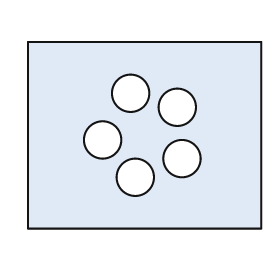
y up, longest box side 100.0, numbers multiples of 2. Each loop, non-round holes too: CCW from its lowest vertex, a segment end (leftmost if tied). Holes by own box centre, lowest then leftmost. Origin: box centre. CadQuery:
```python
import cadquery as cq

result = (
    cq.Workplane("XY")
    .moveTo(-50.0, -40.0)
    .lineTo(50.0, -40.0)
    .lineTo(50.0, 40.0)
    .lineTo(-50.0, 40.0)
    .close()
    .moveTo(-4.0, -18.0)
    .circle(8.0)
    .moveTo(16.0, -10.0)
    .circle(8.0)
    .moveTo(-18.0, -2.0)
    .circle(8.0)
    .moveTo(14.0, 12.0)
    .circle(8.0)
    .moveTo(-6.0, 18.0)
    .circle(8.0)
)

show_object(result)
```